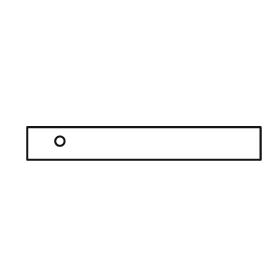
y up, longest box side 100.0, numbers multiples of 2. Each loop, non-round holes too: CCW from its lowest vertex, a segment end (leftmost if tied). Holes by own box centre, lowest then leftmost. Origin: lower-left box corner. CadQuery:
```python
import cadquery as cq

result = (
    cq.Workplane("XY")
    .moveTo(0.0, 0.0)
    .lineTo(100.0, 0.0)
    .lineTo(100.0, 14.0)
    .lineTo(0.0, 14.0)
    .close()
    .moveTo(14.0, 8.0)
    .circle(2.0)
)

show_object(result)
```